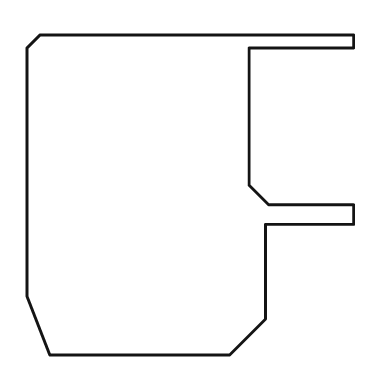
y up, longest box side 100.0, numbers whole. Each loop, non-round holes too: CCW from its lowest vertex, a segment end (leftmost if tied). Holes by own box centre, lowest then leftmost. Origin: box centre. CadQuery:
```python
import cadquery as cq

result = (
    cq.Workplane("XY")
    .moveTo(-43.0, -49.0)
    .lineTo(12.0, -49.0)
    .lineTo(23.0, -38.0)
    .lineTo(23.0, -9.0)
    .lineTo(50.0, -9.0)
    .lineTo(50.0, -3.0)
    .lineTo(24.0, -3.0)
    .lineTo(18.0, 3.0)
    .lineTo(18.0, 45.0)
    .lineTo(50.0, 45.0)
    .lineTo(50.0, 49.0)
    .lineTo(-46.0, 49.0)
    .lineTo(-50.0, 45.0)
    .lineTo(-50.0, -31.0)
    .close()
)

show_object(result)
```